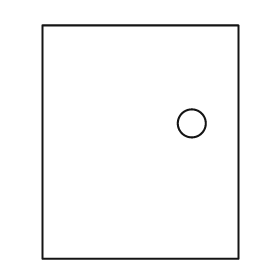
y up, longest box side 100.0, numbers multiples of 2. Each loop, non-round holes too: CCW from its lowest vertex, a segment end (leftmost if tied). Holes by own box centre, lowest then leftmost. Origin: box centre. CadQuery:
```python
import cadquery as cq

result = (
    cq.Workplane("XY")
    .moveTo(-42.0, -50.0)
    .lineTo(42.0, -50.0)
    .lineTo(42.0, 50.0)
    .lineTo(-42.0, 50.0)
    .close()
    .moveTo(22.0, 8.0)
    .circle(6.0)
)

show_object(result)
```